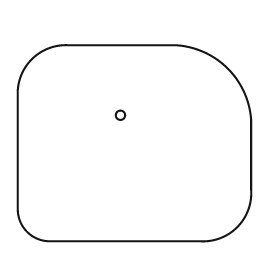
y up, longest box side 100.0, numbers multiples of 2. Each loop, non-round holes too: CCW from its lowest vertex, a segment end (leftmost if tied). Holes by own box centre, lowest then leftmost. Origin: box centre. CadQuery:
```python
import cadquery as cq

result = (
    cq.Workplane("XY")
    .moveTo(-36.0, -42.0)
    .lineTo(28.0, -42.0)
    .threePointArc((44.0, -36.0), (50.0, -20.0))
    .lineTo(50.0, 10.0)
    .threePointArc((40.0, 32.0), (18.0, 42.0))
    .lineTo(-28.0, 42.0)
    .threePointArc((-44.0, 36.0), (-50.0, 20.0))
    .lineTo(-50.0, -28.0)
    .threePointArc((-46.0, -38.0), (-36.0, -42.0))
    .close()
    .moveTo(-6.0, 12.0)
    .circle(2.0)
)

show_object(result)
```